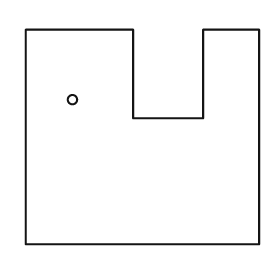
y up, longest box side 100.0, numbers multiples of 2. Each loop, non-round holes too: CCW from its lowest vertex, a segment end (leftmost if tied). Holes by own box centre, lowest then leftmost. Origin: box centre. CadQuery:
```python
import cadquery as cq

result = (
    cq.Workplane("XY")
    .moveTo(-50.0, -46.0)
    .lineTo(50.0, -46.0)
    .lineTo(50.0, 46.0)
    .lineTo(26.0, 46.0)
    .lineTo(26.0, 8.0)
    .lineTo(-4.0, 8.0)
    .lineTo(-4.0, 46.0)
    .lineTo(-50.0, 46.0)
    .close()
    .moveTo(-30.0, 16.0)
    .circle(2.0)
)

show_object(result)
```